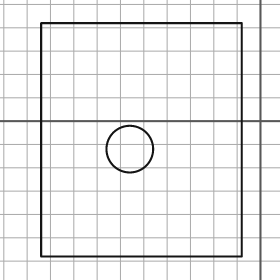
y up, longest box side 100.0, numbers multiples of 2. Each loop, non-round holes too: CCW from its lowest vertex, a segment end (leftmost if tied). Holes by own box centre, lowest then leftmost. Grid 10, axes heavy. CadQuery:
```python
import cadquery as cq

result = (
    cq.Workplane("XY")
    .moveTo(-94.0, -58.0)
    .lineTo(-8.0, -58.0)
    .lineTo(-8.0, 42.0)
    .lineTo(-94.0, 42.0)
    .close()
    .moveTo(-56.0, -12.0)
    .circle(10.0)
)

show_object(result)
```